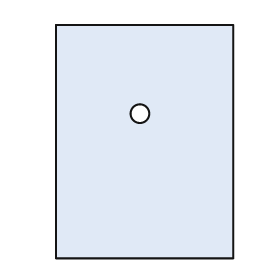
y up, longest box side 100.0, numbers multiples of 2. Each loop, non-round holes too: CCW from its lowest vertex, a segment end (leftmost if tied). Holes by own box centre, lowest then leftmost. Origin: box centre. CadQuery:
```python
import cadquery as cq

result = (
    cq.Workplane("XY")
    .moveTo(-38.0, -50.0)
    .lineTo(38.0, -50.0)
    .lineTo(38.0, 50.0)
    .lineTo(-38.0, 50.0)
    .close()
    .moveTo(-2.0, 12.0)
    .circle(4.0)
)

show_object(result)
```